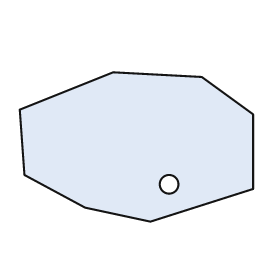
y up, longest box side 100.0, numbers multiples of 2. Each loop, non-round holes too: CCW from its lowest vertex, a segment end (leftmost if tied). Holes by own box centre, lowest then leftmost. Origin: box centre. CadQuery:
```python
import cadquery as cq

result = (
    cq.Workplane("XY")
    .moveTo(6.0, -32.0)
    .lineTo(50.0, -18.0)
    .lineTo(50.0, 14.0)
    .lineTo(28.0, 30.0)
    .lineTo(-10.0, 32.0)
    .lineTo(-50.0, 16.0)
    .lineTo(-48.0, -12.0)
    .lineTo(-22.0, -26.0)
    .close()
    .moveTo(14.0, -16.0)
    .circle(4.0)
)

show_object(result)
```